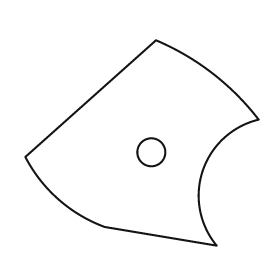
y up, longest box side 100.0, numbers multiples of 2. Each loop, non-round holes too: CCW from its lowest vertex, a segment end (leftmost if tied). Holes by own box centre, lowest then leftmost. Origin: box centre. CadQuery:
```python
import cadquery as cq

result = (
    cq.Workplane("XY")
    .moveTo(32.0, -44.0)
    .threePointArc((26.0, -12.0), (50.0, 10.0))
    .threePointArc((30.0, 30.0), (6.0, 44.0))
    .lineTo(-50.0, -6.0)
    .threePointArc((-36.0, -24.0), (-16.0, -36.0))
    .close()
    .moveTo(4.0, -4.0)
    .circle(6.0)
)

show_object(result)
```